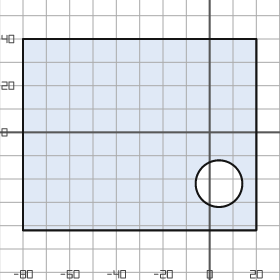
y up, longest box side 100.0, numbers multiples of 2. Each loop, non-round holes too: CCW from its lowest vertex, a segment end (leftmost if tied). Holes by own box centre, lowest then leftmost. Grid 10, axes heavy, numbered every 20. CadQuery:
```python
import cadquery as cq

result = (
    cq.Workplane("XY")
    .moveTo(-80.0, -42.0)
    .lineTo(20.0, -42.0)
    .lineTo(20.0, 40.0)
    .lineTo(-80.0, 40.0)
    .close()
    .moveTo(4.0, -22.0)
    .circle(10.0)
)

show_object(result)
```